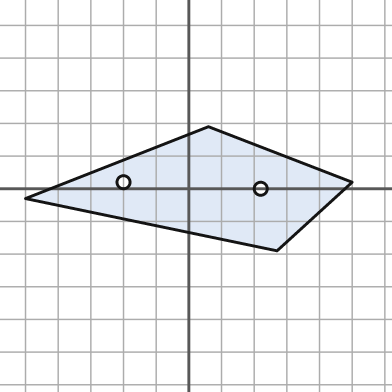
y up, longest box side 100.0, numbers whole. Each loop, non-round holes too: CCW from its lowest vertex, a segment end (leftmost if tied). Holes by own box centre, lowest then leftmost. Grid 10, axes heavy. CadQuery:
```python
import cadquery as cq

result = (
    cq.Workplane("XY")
    .moveTo(27.0, -19.0)
    .lineTo(50.0, 2.0)
    .lineTo(6.0, 19.0)
    .lineTo(-50.0, -3.0)
    .close()
    .moveTo(22.0, 0.0)
    .circle(2.0)
    .moveTo(-20.0, 2.0)
    .circle(2.0)
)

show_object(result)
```